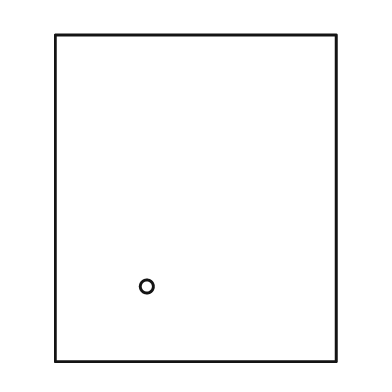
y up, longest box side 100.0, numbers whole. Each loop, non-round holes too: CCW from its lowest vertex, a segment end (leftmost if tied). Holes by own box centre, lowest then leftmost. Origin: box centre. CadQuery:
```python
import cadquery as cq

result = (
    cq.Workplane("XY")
    .moveTo(-43.0, -50.0)
    .lineTo(43.0, -50.0)
    .lineTo(43.0, 50.0)
    .lineTo(-43.0, 50.0)
    .close()
    .moveTo(-15.0, -27.0)
    .circle(2.0)
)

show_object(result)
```